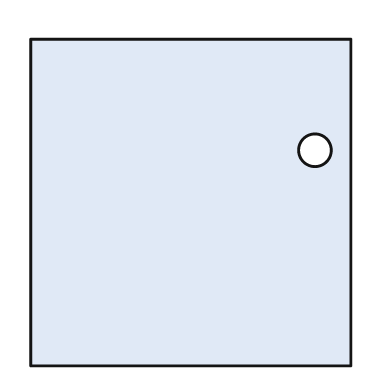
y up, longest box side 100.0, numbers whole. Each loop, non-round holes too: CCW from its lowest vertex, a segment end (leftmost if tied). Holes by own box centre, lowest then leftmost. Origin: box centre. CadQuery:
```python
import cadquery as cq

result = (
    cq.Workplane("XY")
    .moveTo(-49.0, -50.0)
    .lineTo(49.0, -50.0)
    .lineTo(49.0, 50.0)
    .lineTo(-49.0, 50.0)
    .close()
    .moveTo(38.0, 16.0)
    .circle(5.0)
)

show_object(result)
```